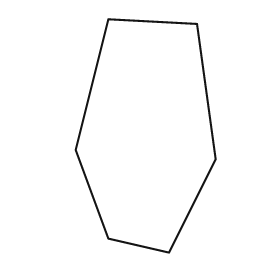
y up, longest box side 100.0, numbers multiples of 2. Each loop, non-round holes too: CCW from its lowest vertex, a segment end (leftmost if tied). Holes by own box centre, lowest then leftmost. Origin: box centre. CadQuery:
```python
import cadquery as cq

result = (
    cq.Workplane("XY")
    .moveTo(10.0, -50.0)
    .lineTo(30.0, -10.0)
    .lineTo(22.0, 48.0)
    .lineTo(-16.0, 50.0)
    .lineTo(-30.0, -6.0)
    .lineTo(-16.0, -44.0)
    .close()
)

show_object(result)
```